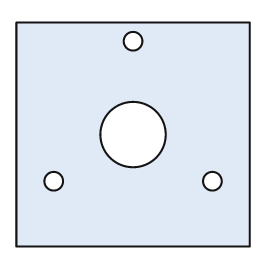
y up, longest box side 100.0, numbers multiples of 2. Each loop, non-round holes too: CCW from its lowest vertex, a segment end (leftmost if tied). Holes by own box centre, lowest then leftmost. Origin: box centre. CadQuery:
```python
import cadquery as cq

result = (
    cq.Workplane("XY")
    .moveTo(-50.0, -48.0)
    .lineTo(50.0, -48.0)
    .lineTo(50.0, 48.0)
    .lineTo(-50.0, 48.0)
    .close()
    .moveTo(-34.0, -20.0)
    .circle(4.0)
    .moveTo(34.0, -20.0)
    .circle(4.0)
    .moveTo(0.0, 0.0)
    .circle(14.0)
    .moveTo(0.0, 40.0)
    .circle(4.0)
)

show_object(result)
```